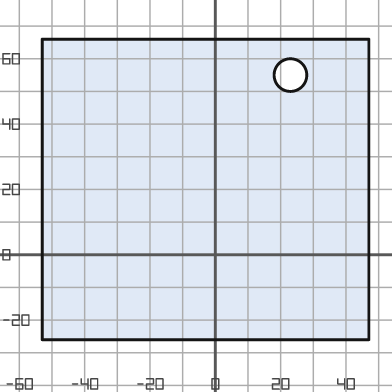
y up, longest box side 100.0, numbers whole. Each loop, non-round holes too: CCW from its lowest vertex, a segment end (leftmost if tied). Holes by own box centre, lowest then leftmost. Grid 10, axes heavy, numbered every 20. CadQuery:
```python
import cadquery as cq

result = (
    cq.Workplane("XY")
    .moveTo(-53.0, -26.0)
    .lineTo(47.0, -26.0)
    .lineTo(47.0, 66.0)
    .lineTo(-53.0, 66.0)
    .close()
    .moveTo(23.0, 55.0)
    .circle(5.0)
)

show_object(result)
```